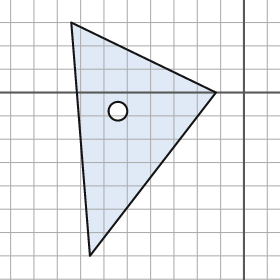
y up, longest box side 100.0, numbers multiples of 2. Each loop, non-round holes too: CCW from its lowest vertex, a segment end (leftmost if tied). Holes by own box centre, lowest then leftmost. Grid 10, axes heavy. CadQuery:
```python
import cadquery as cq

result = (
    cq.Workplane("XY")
    .moveTo(-66.0, -70.0)
    .lineTo(-12.0, 0.0)
    .lineTo(-74.0, 30.0)
    .close()
    .moveTo(-54.0, -8.0)
    .circle(4.0)
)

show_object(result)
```